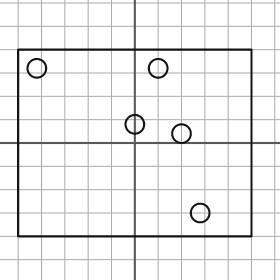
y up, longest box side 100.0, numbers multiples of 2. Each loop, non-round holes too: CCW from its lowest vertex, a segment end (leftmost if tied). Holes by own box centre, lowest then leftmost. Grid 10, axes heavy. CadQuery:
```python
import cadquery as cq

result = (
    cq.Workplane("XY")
    .moveTo(-50.0, -40.0)
    .lineTo(50.0, -40.0)
    .lineTo(50.0, 40.0)
    .lineTo(-50.0, 40.0)
    .close()
    .moveTo(28.0, -30.0)
    .circle(4.0)
    .moveTo(20.0, 4.0)
    .circle(4.0)
    .moveTo(0.0, 8.0)
    .circle(4.0)
    .moveTo(-42.0, 32.0)
    .circle(4.0)
    .moveTo(10.0, 32.0)
    .circle(4.0)
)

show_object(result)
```